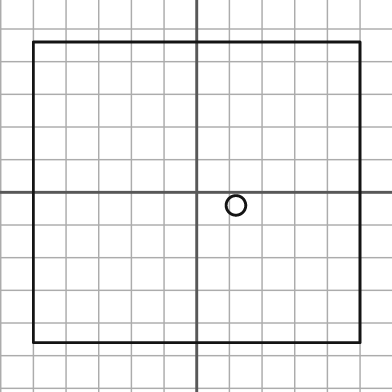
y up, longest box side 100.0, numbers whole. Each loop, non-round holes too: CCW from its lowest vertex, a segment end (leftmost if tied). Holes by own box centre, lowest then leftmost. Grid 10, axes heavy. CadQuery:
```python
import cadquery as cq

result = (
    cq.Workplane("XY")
    .moveTo(-50.0, -46.0)
    .lineTo(50.0, -46.0)
    .lineTo(50.0, 46.0)
    .lineTo(-50.0, 46.0)
    .close()
    .moveTo(12.0, -4.0)
    .circle(3.0)
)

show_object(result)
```